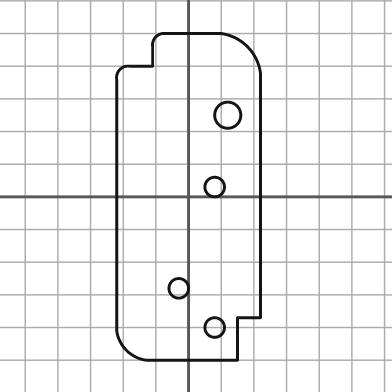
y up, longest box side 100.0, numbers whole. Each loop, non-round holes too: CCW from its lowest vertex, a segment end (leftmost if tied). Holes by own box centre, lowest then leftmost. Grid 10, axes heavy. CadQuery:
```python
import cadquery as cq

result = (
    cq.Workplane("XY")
    .moveTo(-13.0, -50.0)
    .lineTo(15.0, -50.0)
    .lineTo(15.0, -37.0)
    .lineTo(22.0, -37.0)
    .lineTo(22.0, 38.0)
    .threePointArc((18.0, 46.0), (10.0, 50.0))
    .lineTo(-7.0, 50.0)
    .threePointArc((-10.0, 49.0), (-11.0, 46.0))
    .lineTo(-11.0, 40.0)
    .lineTo(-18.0, 40.0)
    .threePointArc((-21.0, 39.0), (-22.0, 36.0))
    .lineTo(-22.0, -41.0)
    .threePointArc((-19.0, -47.0), (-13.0, -50.0))
    .close()
    .moveTo(8.0, -40.0)
    .circle(3.0)
    .moveTo(-3.0, -28.0)
    .circle(3.0)
    .moveTo(8.0, 3.0)
    .circle(3.0)
    .moveTo(12.0, 25.0)
    .circle(4.0)
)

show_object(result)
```